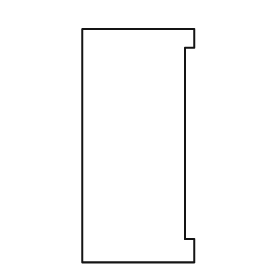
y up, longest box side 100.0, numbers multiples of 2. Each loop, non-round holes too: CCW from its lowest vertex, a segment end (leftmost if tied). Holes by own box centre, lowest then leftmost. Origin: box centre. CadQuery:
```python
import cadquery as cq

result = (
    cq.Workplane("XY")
    .moveTo(-24.0, -50.0)
    .lineTo(24.0, -50.0)
    .lineTo(24.0, -40.0)
    .lineTo(20.0, -40.0)
    .lineTo(20.0, 42.0)
    .lineTo(24.0, 42.0)
    .lineTo(24.0, 50.0)
    .lineTo(-24.0, 50.0)
    .close()
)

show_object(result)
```